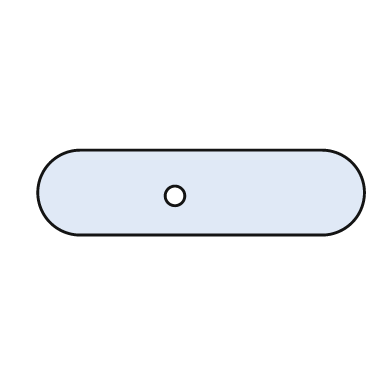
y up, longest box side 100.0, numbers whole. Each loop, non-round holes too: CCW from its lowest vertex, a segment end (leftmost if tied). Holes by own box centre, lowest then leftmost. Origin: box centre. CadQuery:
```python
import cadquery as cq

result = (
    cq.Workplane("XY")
    .moveTo(-37.0, -13.0)
    .lineTo(37.0, -13.0)
    .threePointArc((50.0, 0.0), (37.0, 13.0))
    .lineTo(-37.0, 13.0)
    .threePointArc((-50.0, 0.0), (-37.0, -13.0))
    .close()
    .moveTo(-8.0, -1.0)
    .circle(3.0)
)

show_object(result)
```